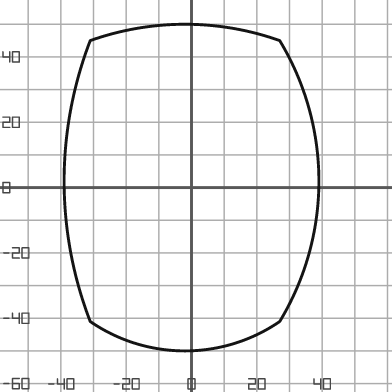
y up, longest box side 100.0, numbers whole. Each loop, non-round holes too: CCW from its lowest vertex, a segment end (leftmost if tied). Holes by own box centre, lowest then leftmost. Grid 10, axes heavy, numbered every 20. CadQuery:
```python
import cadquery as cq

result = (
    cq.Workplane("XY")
    .moveTo(-31.0, -41.0)
    .threePointArc((-2.0, -50.0), (27.0, -41.0))
    .threePointArc((39.0, 2.0), (27.0, 45.0))
    .threePointArc((-2.0, 50.0), (-31.0, 45.0))
    .threePointArc((-39.0, 2.0), (-31.0, -41.0))
    .close()
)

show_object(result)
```